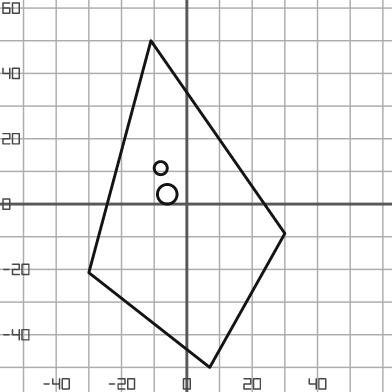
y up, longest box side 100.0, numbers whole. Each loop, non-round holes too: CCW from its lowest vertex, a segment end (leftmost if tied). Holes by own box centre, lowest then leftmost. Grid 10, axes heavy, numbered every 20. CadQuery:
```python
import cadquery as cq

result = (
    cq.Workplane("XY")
    .moveTo(7.0, -50.0)
    .lineTo(30.0, -9.0)
    .lineTo(-11.0, 50.0)
    .lineTo(-30.0, -21.0)
    .close()
    .moveTo(-6.0, 3.0)
    .circle(3.0)
    .moveTo(-8.0, 11.0)
    .circle(2.0)
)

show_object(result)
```